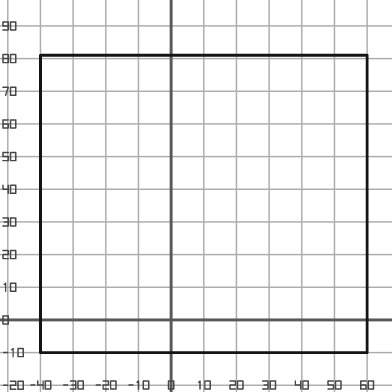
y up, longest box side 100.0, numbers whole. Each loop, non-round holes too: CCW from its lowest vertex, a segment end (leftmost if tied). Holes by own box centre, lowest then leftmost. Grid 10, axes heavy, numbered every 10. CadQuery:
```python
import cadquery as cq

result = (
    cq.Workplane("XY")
    .moveTo(-40.0, -10.0)
    .lineTo(60.0, -10.0)
    .lineTo(60.0, 81.0)
    .lineTo(-40.0, 81.0)
    .close()
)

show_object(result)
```